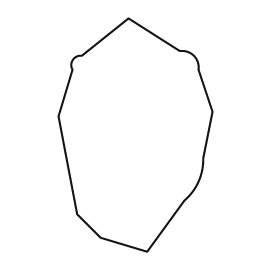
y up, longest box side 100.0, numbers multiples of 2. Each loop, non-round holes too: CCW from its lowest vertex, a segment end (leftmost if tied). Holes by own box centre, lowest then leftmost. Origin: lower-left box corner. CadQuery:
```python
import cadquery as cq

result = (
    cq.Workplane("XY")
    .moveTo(38.0, 0.0)
    .lineTo(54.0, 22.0)
    .threePointArc((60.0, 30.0), (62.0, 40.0))
    .lineTo(66.0, 60.0)
    .lineTo(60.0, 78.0)
    .threePointArc((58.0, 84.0), (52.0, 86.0))
    .lineTo(30.0, 100.0)
    .lineTo(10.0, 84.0)
    .threePointArc((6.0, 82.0), (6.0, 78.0))
    .lineTo(0.0, 58.0)
    .lineTo(8.0, 16.0)
    .lineTo(18.0, 6.0)
    .close()
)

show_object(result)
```